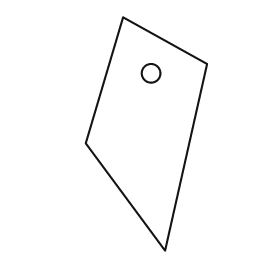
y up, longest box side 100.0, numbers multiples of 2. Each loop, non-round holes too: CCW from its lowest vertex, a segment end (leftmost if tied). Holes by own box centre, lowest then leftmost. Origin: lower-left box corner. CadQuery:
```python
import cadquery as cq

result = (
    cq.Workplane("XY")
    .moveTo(34.0, 0.0)
    .lineTo(52.0, 80.0)
    .lineTo(16.0, 100.0)
    .lineTo(0.0, 46.0)
    .close()
    .moveTo(28.0, 76.0)
    .circle(4.0)
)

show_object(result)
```